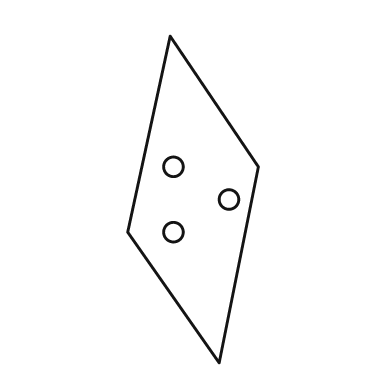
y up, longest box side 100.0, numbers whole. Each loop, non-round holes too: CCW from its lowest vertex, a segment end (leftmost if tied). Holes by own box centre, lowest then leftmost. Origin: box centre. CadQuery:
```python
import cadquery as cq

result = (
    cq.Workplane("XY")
    .moveTo(8.0, -50.0)
    .lineTo(20.0, 10.0)
    .lineTo(-7.0, 50.0)
    .lineTo(-20.0, -10.0)
    .close()
    .moveTo(-6.0, -10.0)
    .circle(3.0)
    .moveTo(11.0, 0.0)
    .circle(3.0)
    .moveTo(-6.0, 10.0)
    .circle(3.0)
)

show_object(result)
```